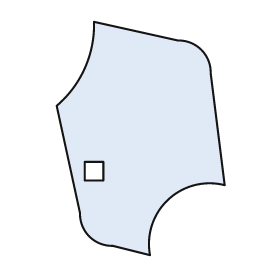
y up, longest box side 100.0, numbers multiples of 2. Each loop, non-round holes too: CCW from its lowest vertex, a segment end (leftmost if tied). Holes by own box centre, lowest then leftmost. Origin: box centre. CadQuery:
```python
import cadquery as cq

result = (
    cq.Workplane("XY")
    .moveTo(4.0, -50.0)
    .threePointArc((12.0, -26.0), (36.0, -20.0))
    .lineTo(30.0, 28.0)
    .threePointArc((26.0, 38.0), (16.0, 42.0))
    .lineTo(-20.0, 50.0)
    .threePointArc((-24.0, 30.0), (-36.0, 14.0))
    .lineTo(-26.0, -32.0)
    .threePointArc((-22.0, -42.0), (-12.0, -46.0))
    .close()
    .moveTo(-24.0, -18.0)
    .lineTo(-16.0, -18.0)
    .lineTo(-16.0, -10.0)
    .lineTo(-24.0, -10.0)
    .close()
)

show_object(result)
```